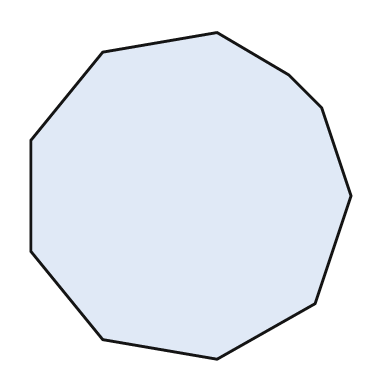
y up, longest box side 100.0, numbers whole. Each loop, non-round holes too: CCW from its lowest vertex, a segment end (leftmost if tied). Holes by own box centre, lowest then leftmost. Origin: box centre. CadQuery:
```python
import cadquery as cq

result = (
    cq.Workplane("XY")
    .moveTo(8.0, -50.0)
    .lineTo(38.0, -33.0)
    .lineTo(49.0, 0.0)
    .lineTo(40.0, 27.0)
    .lineTo(30.0, 37.0)
    .lineTo(8.0, 50.0)
    .lineTo(-27.0, 44.0)
    .lineTo(-49.0, 17.0)
    .lineTo(-49.0, -17.0)
    .lineTo(-27.0, -44.0)
    .close()
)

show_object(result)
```